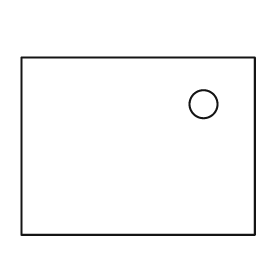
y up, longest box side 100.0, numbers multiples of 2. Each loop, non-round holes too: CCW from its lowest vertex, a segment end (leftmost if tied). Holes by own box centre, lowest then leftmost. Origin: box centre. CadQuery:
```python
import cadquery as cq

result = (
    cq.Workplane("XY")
    .moveTo(-50.0, -38.0)
    .lineTo(50.0, -38.0)
    .lineTo(50.0, 38.0)
    .lineTo(-50.0, 38.0)
    .close()
    .moveTo(28.0, 18.0)
    .circle(6.0)
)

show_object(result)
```